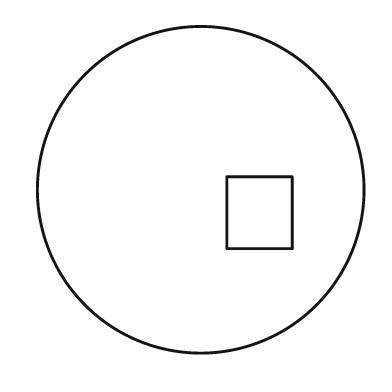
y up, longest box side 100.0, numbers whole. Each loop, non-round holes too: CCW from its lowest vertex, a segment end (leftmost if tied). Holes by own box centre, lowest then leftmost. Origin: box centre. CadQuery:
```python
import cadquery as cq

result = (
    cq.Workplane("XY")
    .moveTo(0.0, 0.0)
    .circle(50.0)
    .moveTo(8.0, -18.0)
    .lineTo(28.0, -18.0)
    .lineTo(28.0, 4.0)
    .lineTo(8.0, 4.0)
    .close()
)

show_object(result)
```